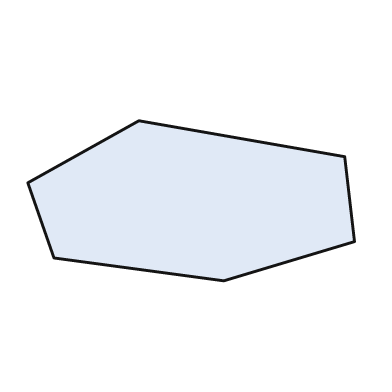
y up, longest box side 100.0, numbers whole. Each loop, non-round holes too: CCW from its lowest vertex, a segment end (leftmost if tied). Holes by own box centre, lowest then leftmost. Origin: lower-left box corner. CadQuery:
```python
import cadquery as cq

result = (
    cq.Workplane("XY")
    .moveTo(60.0, 0.0)
    .lineTo(100.0, 12.0)
    .lineTo(97.0, 38.0)
    .lineTo(34.0, 49.0)
    .lineTo(0.0, 30.0)
    .lineTo(8.0, 7.0)
    .close()
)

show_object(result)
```